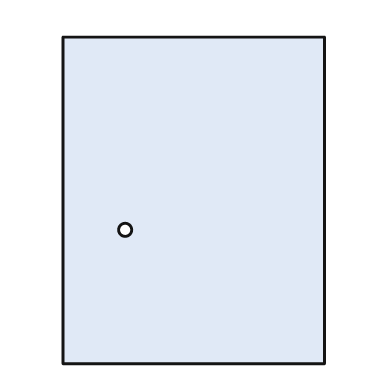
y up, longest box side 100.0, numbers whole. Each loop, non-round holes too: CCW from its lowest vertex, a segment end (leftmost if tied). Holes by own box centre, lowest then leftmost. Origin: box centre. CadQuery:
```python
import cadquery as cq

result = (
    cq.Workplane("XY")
    .moveTo(-40.0, -50.0)
    .lineTo(40.0, -50.0)
    .lineTo(40.0, 50.0)
    .lineTo(-40.0, 50.0)
    .close()
    .moveTo(-21.0, -9.0)
    .circle(2.0)
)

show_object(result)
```